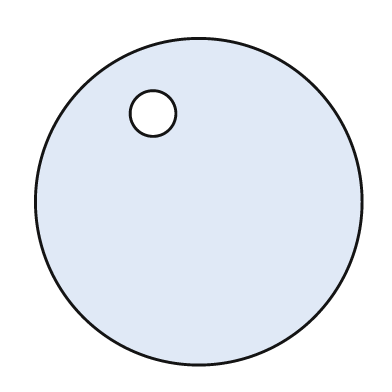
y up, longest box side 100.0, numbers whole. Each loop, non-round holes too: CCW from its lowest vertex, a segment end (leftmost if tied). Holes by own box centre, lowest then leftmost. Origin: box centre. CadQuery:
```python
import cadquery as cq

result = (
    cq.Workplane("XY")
    .moveTo(0.0, 0.0)
    .circle(50.0)
    .moveTo(-14.0, 27.0)
    .circle(7.0)
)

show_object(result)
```